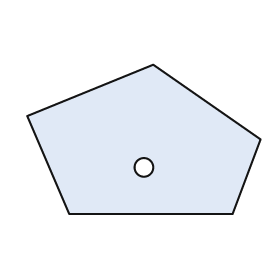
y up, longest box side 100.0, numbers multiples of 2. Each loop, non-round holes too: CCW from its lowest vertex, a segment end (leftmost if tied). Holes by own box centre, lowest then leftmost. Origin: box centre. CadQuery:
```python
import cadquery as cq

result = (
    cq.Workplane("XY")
    .moveTo(-32.0, -32.0)
    .lineTo(38.0, -32.0)
    .lineTo(50.0, 0.0)
    .lineTo(4.0, 32.0)
    .lineTo(-50.0, 10.0)
    .close()
    .moveTo(0.0, -12.0)
    .circle(4.0)
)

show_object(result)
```